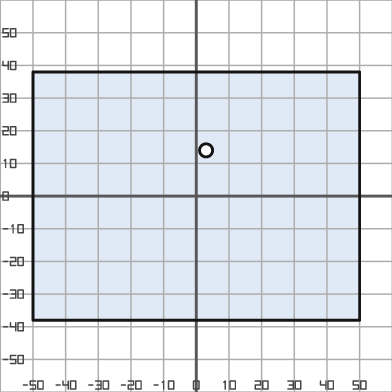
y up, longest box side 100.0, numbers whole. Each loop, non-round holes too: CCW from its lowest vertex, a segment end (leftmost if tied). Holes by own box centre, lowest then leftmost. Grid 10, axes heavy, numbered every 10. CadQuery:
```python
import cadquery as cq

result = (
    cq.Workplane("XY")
    .moveTo(-50.0, -38.0)
    .lineTo(50.0, -38.0)
    .lineTo(50.0, 38.0)
    .lineTo(-50.0, 38.0)
    .close()
    .moveTo(3.0, 14.0)
    .circle(2.0)
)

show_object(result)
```